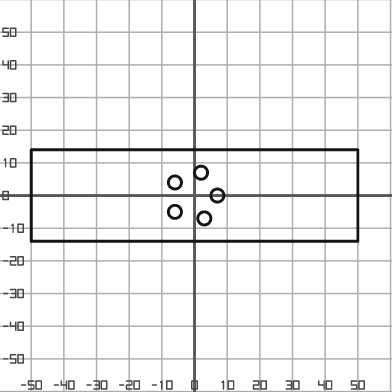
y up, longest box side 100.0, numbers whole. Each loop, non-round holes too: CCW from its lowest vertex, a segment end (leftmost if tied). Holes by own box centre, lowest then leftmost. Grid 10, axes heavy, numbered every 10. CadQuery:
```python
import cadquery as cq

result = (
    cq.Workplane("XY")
    .moveTo(-50.0, -14.0)
    .lineTo(50.0, -14.0)
    .lineTo(50.0, 14.0)
    .lineTo(-50.0, 14.0)
    .close()
    .moveTo(3.0, -7.0)
    .circle(2.0)
    .moveTo(-6.0, -5.0)
    .circle(2.0)
    .moveTo(7.0, 0.0)
    .circle(2.0)
    .moveTo(-6.0, 4.0)
    .circle(2.0)
    .moveTo(2.0, 7.0)
    .circle(2.0)
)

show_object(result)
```